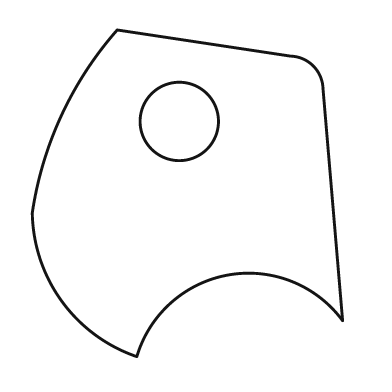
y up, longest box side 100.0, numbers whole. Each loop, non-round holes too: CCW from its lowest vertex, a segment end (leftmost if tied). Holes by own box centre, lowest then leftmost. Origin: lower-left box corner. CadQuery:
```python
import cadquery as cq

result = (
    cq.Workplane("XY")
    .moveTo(32.0, 0.0)
    .threePointArc((60.0, 25.0), (95.0, 11.0))
    .lineTo(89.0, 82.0)
    .threePointArc((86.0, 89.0), (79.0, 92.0))
    .lineTo(26.0, 100.0)
    .threePointArc((9.0, 74.0), (0.0, 44.0))
    .threePointArc((9.0, 17.0), (32.0, 0.0))
    .close()
    .moveTo(45.0, 72.0)
    .circle(12.0)
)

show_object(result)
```